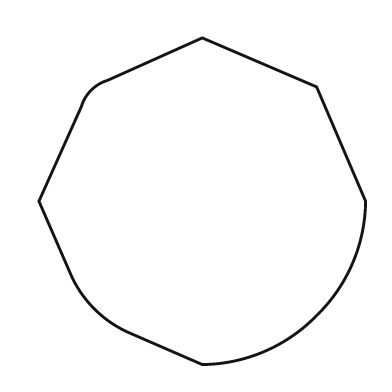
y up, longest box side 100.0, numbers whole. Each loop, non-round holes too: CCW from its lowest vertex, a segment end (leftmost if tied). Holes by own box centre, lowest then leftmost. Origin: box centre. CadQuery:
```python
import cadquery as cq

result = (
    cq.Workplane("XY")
    .moveTo(0.0, -50.0)
    .threePointArc((19.0, -46.0), (35.0, -35.0))
    .threePointArc((46.0, -19.0), (50.0, 0.0))
    .lineTo(35.0, 35.0)
    .lineTo(0.0, 50.0)
    .lineTo(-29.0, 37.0)
    .threePointArc((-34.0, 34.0), (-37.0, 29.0))
    .lineTo(-50.0, 0.0)
    .lineTo(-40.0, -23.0)
    .threePointArc((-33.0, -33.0), (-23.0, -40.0))
    .close()
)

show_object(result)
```